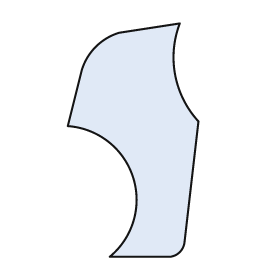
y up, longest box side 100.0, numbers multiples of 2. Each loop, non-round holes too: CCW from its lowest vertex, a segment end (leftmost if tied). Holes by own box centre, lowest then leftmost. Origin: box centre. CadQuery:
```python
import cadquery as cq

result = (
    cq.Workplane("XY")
    .moveTo(-10.0, -50.0)
    .lineTo(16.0, -50.0)
    .threePointArc((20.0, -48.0), (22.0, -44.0))
    .lineTo(28.0, 8.0)
    .threePointArc((18.0, 28.0), (20.0, 50.0))
    .lineTo(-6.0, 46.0)
    .threePointArc((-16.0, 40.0), (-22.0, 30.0))
    .lineTo(-28.0, 6.0)
    .threePointArc((0.0, -16.0), (-10.0, -50.0))
    .close()
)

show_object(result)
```